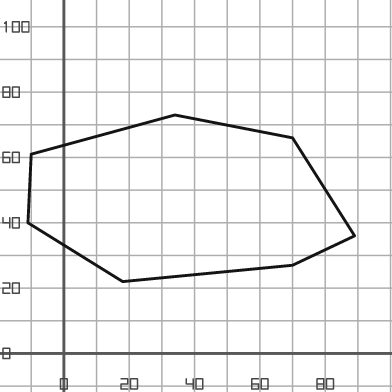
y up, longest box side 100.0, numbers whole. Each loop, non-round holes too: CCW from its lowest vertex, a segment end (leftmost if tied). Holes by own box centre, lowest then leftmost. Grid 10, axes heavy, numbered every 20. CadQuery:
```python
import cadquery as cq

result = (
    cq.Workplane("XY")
    .moveTo(18.0, 22.0)
    .lineTo(70.0, 27.0)
    .lineTo(89.0, 36.0)
    .lineTo(70.0, 66.0)
    .lineTo(34.0, 73.0)
    .lineTo(-10.0, 61.0)
    .lineTo(-11.0, 40.0)
    .close()
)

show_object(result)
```